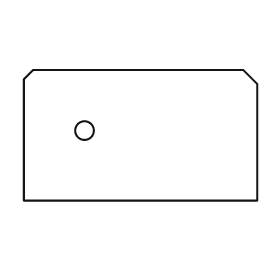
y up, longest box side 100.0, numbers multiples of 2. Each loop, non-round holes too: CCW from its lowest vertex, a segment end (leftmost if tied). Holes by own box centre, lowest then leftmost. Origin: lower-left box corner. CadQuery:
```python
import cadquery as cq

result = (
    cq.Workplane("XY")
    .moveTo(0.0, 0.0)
    .lineTo(100.0, 0.0)
    .lineTo(100.0, 50.0)
    .lineTo(94.0, 56.0)
    .lineTo(4.0, 56.0)
    .lineTo(0.0, 52.0)
    .close()
    .moveTo(26.0, 30.0)
    .circle(4.0)
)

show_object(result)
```